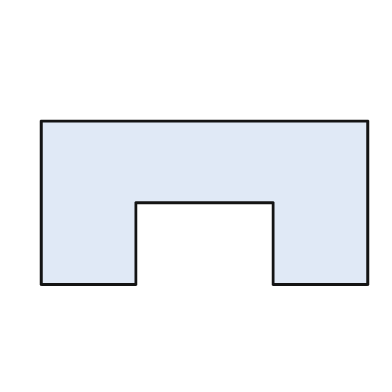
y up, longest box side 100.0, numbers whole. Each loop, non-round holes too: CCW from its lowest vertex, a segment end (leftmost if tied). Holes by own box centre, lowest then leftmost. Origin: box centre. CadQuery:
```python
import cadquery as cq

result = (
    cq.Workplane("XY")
    .moveTo(-50.0, -25.0)
    .lineTo(-21.0, -25.0)
    .lineTo(-21.0, 0.0)
    .lineTo(21.0, 0.0)
    .lineTo(21.0, -25.0)
    .lineTo(50.0, -25.0)
    .lineTo(50.0, 25.0)
    .lineTo(-50.0, 25.0)
    .close()
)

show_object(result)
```